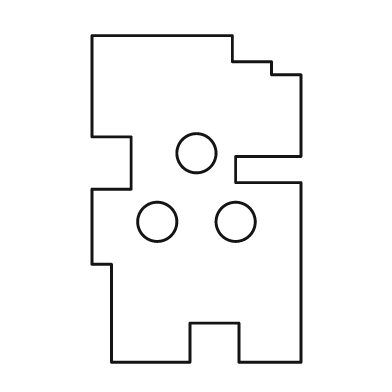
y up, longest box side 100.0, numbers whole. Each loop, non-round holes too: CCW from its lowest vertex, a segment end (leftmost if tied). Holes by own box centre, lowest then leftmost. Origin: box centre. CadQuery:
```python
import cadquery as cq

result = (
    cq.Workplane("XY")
    .moveTo(-26.0, -50.0)
    .lineTo(-2.0, -50.0)
    .lineTo(-2.0, -38.0)
    .lineTo(13.0, -38.0)
    .lineTo(13.0, -50.0)
    .lineTo(32.0, -50.0)
    .lineTo(32.0, 5.0)
    .lineTo(12.0, 5.0)
    .lineTo(12.0, 13.0)
    .lineTo(32.0, 13.0)
    .lineTo(32.0, 38.0)
    .lineTo(23.0, 38.0)
    .lineTo(23.0, 42.0)
    .lineTo(11.0, 42.0)
    .lineTo(11.0, 50.0)
    .lineTo(-32.0, 50.0)
    .lineTo(-32.0, 19.0)
    .lineTo(-20.0, 19.0)
    .lineTo(-20.0, 3.0)
    .lineTo(-32.0, 3.0)
    .lineTo(-32.0, -20.0)
    .lineTo(-26.0, -20.0)
    .close()
    .moveTo(-12.0, -7.0)
    .circle(6.0)
    .moveTo(12.0, -7.0)
    .circle(6.0)
    .moveTo(0.0, 14.0)
    .circle(6.0)
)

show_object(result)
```